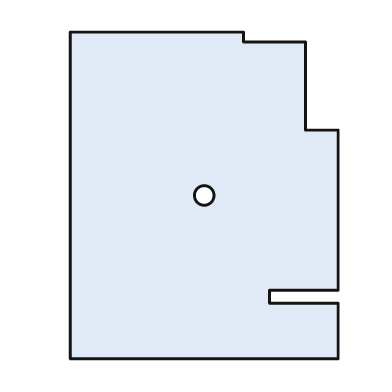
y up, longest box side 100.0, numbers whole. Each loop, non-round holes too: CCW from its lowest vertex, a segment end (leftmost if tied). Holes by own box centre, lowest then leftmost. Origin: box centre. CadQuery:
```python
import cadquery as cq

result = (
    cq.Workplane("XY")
    .moveTo(-41.0, -50.0)
    .lineTo(41.0, -50.0)
    .lineTo(41.0, -33.0)
    .lineTo(20.0, -33.0)
    .lineTo(20.0, -29.0)
    .lineTo(41.0, -29.0)
    .lineTo(41.0, 20.0)
    .lineTo(31.0, 20.0)
    .lineTo(31.0, 47.0)
    .lineTo(12.0, 47.0)
    .lineTo(12.0, 50.0)
    .lineTo(-41.0, 50.0)
    .close()
    .moveTo(0.0, 0.0)
    .circle(3.0)
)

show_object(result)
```